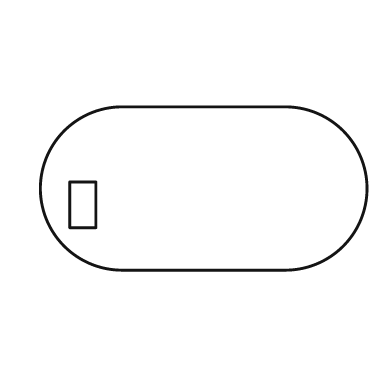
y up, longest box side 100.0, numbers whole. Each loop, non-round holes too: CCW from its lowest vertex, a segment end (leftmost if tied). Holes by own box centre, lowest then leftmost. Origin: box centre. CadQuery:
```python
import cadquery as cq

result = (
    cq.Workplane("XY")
    .moveTo(-25.0, -25.0)
    .lineTo(25.0, -25.0)
    .threePointArc((50.0, 0.0), (25.0, 25.0))
    .lineTo(-25.0, 25.0)
    .threePointArc((-50.0, 0.0), (-25.0, -25.0))
    .close()
    .moveTo(-41.0, -12.0)
    .lineTo(-33.0, -12.0)
    .lineTo(-33.0, 2.0)
    .lineTo(-41.0, 2.0)
    .close()
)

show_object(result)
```